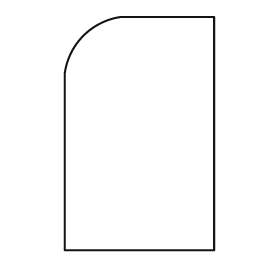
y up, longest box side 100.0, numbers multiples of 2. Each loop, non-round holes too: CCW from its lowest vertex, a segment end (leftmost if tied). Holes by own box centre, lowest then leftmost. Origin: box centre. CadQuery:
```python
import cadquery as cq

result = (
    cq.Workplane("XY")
    .moveTo(-32.0, -50.0)
    .lineTo(32.0, -50.0)
    .lineTo(32.0, 50.0)
    .lineTo(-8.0, 50.0)
    .threePointArc((-24.0, 42.0), (-32.0, 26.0))
    .close()
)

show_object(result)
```